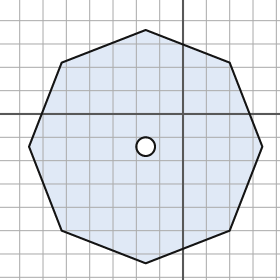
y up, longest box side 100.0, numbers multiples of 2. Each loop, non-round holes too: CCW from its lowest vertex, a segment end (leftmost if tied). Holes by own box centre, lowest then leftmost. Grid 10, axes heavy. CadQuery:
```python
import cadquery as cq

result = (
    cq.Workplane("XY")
    .moveTo(-16.0, -64.0)
    .lineTo(20.0, -50.0)
    .lineTo(34.0, -14.0)
    .lineTo(20.0, 22.0)
    .lineTo(-16.0, 36.0)
    .lineTo(-52.0, 22.0)
    .lineTo(-66.0, -14.0)
    .lineTo(-52.0, -50.0)
    .close()
    .moveTo(-16.0, -14.0)
    .circle(4.0)
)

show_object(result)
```